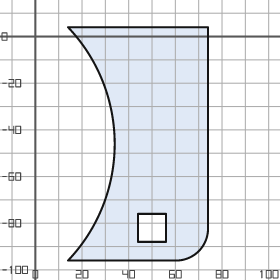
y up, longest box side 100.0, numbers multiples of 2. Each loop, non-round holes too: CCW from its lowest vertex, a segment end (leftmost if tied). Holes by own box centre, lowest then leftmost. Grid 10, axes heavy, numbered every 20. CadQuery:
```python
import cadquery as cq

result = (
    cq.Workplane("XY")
    .moveTo(14.0, -96.0)
    .lineTo(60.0, -96.0)
    .threePointArc((70.0, -92.0), (74.0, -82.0))
    .lineTo(74.0, 4.0)
    .lineTo(14.0, 4.0)
    .threePointArc((34.0, -46.0), (14.0, -96.0))
    .close()
    .moveTo(44.0, -88.0)
    .lineTo(56.0, -88.0)
    .lineTo(56.0, -76.0)
    .lineTo(44.0, -76.0)
    .close()
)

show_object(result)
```